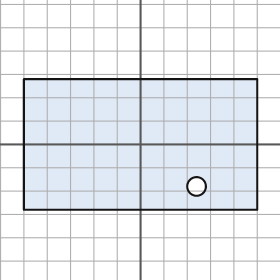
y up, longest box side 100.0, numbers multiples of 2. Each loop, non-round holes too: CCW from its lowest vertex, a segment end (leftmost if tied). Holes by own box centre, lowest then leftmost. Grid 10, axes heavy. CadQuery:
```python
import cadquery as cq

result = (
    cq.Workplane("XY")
    .moveTo(-50.0, -28.0)
    .lineTo(50.0, -28.0)
    .lineTo(50.0, 28.0)
    .lineTo(-50.0, 28.0)
    .close()
    .moveTo(24.0, -18.0)
    .circle(4.0)
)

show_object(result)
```